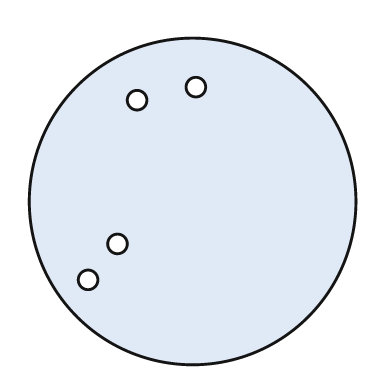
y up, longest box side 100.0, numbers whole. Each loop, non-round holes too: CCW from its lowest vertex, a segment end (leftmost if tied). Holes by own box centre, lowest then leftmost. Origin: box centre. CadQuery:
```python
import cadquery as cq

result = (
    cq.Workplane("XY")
    .moveTo(0.0, 0.0)
    .circle(50.0)
    .moveTo(-32.0, -24.0)
    .circle(3.0)
    .moveTo(-23.0, -13.0)
    .circle(3.0)
    .moveTo(-17.0, 31.0)
    .circle(3.0)
    .moveTo(1.0, 35.0)
    .circle(3.0)
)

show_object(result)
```